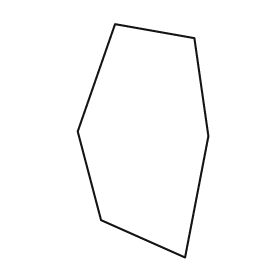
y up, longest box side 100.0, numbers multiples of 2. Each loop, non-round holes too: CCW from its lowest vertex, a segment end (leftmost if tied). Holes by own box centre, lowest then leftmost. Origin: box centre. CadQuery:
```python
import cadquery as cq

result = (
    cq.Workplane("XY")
    .moveTo(18.0, -50.0)
    .lineTo(28.0, 2.0)
    .lineTo(22.0, 44.0)
    .lineTo(-12.0, 50.0)
    .lineTo(-28.0, 4.0)
    .lineTo(-18.0, -34.0)
    .close()
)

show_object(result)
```